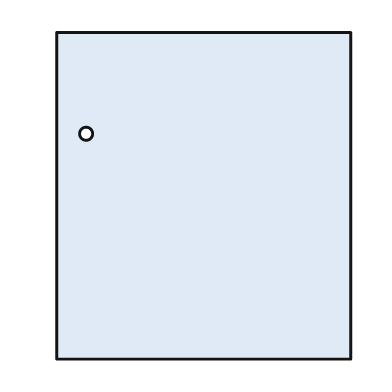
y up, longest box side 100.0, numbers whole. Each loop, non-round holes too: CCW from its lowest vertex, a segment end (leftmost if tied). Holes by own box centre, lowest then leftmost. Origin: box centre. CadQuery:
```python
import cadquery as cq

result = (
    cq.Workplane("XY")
    .moveTo(-45.0, -50.0)
    .lineTo(45.0, -50.0)
    .lineTo(45.0, 50.0)
    .lineTo(-45.0, 50.0)
    .close()
    .moveTo(-36.0, 19.0)
    .circle(2.0)
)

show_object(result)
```